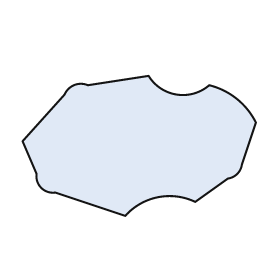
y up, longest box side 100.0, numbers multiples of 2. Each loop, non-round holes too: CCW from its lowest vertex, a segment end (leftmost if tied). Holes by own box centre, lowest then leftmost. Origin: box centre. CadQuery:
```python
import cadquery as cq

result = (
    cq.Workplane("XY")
    .moveTo(-6.0, -30.0)
    .threePointArc((8.0, -22.0), (24.0, -24.0))
    .lineTo(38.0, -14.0)
    .threePointArc((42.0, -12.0), (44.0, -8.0))
    .lineTo(50.0, 10.0)
    .threePointArc((42.0, 20.0), (30.0, 26.0))
    .threePointArc((16.0, 22.0), (4.0, 30.0))
    .lineTo(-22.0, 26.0)
    .threePointArc((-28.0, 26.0), (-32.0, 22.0))
    .lineTo(-50.0, 2.0)
    .lineTo(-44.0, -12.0)
    .threePointArc((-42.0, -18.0), (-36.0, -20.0))
    .close()
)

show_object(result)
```